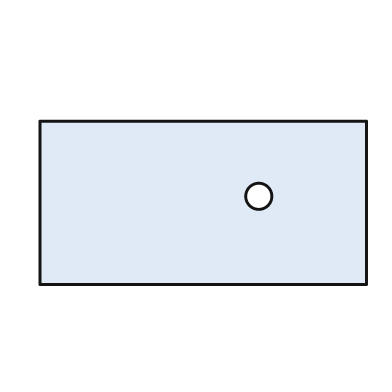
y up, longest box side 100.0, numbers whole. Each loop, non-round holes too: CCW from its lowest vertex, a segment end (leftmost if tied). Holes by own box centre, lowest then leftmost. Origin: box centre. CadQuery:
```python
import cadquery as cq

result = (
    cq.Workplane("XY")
    .moveTo(-50.0, -25.0)
    .lineTo(50.0, -25.0)
    .lineTo(50.0, 25.0)
    .lineTo(-50.0, 25.0)
    .close()
    .moveTo(17.0, 2.0)
    .circle(4.0)
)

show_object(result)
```